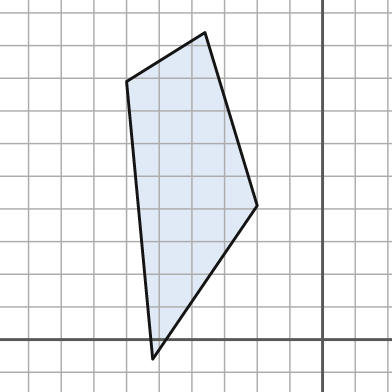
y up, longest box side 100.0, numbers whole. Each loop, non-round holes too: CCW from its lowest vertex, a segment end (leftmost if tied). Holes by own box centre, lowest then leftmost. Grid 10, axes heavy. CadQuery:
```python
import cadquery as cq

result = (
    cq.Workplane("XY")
    .moveTo(-52.0, -6.0)
    .lineTo(-20.0, 41.0)
    .lineTo(-36.0, 94.0)
    .lineTo(-60.0, 79.0)
    .close()
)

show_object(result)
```